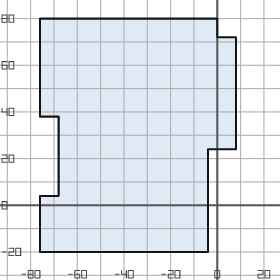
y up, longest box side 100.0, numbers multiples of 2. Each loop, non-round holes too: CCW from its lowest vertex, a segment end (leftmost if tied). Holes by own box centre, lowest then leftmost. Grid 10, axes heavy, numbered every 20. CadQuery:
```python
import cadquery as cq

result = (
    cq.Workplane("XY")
    .moveTo(-76.0, -20.0)
    .lineTo(-4.0, -20.0)
    .lineTo(-4.0, 24.0)
    .lineTo(8.0, 24.0)
    .lineTo(8.0, 72.0)
    .lineTo(0.0, 72.0)
    .lineTo(0.0, 80.0)
    .lineTo(-76.0, 80.0)
    .lineTo(-76.0, 38.0)
    .lineTo(-68.0, 38.0)
    .lineTo(-68.0, 4.0)
    .lineTo(-76.0, 4.0)
    .close()
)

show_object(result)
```